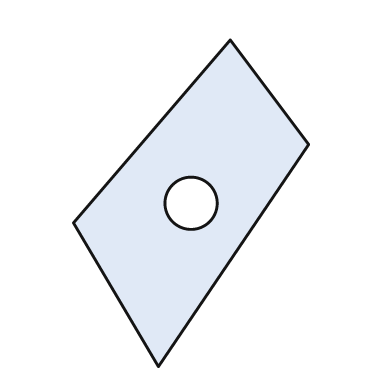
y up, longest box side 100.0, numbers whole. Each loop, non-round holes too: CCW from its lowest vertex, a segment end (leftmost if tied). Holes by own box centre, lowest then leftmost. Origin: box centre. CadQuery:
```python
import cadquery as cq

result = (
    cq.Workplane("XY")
    .moveTo(-10.0, -50.0)
    .lineTo(36.0, 18.0)
    .lineTo(12.0, 50.0)
    .lineTo(-36.0, -6.0)
    .close()
    .moveTo(0.0, 0.0)
    .circle(8.0)
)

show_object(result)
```